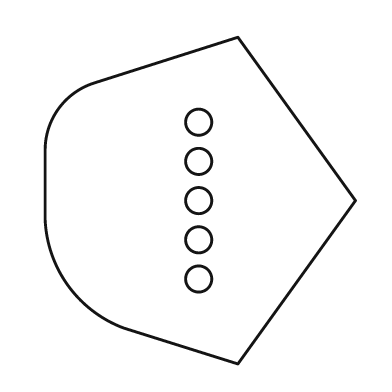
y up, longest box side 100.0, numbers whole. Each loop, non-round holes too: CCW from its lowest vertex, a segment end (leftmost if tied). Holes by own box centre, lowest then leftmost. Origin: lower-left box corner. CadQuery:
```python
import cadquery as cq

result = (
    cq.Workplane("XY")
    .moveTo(59.0, 0.0)
    .lineTo(95.0, 50.0)
    .lineTo(59.0, 100.0)
    .lineTo(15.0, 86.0)
    .threePointArc((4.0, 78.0), (0.0, 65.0))
    .lineTo(0.0, 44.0)
    .threePointArc((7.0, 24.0), (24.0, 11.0))
    .close()
    .moveTo(47.0, 26.0)
    .circle(4.0)
    .moveTo(47.0, 38.0)
    .circle(4.0)
    .moveTo(47.0, 50.0)
    .circle(4.0)
    .moveTo(47.0, 62.0)
    .circle(4.0)
    .moveTo(47.0, 74.0)
    .circle(4.0)
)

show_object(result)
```